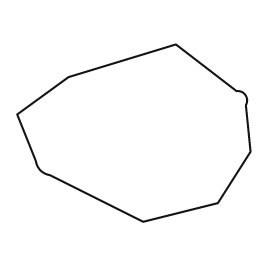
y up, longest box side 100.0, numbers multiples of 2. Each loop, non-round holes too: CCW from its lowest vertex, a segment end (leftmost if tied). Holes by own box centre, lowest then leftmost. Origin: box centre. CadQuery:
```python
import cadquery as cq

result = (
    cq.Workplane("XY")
    .moveTo(4.0, -38.0)
    .lineTo(36.0, -30.0)
    .lineTo(50.0, -8.0)
    .lineTo(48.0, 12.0)
    .threePointArc((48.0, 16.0), (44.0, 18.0))
    .lineTo(18.0, 38.0)
    .lineTo(-28.0, 24.0)
    .lineTo(-50.0, 8.0)
    .lineTo(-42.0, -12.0)
    .threePointArc((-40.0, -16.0), (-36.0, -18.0))
    .close()
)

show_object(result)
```